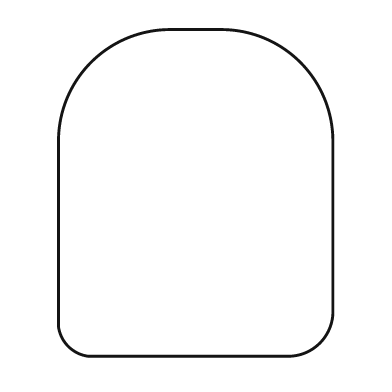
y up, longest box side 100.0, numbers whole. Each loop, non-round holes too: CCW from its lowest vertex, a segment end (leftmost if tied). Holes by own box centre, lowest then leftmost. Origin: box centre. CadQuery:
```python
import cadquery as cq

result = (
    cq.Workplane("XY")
    .moveTo(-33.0, -50.0)
    .lineTo(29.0, -50.0)
    .threePointArc((38.0, -46.0), (42.0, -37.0))
    .lineTo(42.0, 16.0)
    .threePointArc((32.0, 40.0), (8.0, 50.0))
    .lineTo(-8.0, 50.0)
    .threePointArc((-32.0, 40.0), (-42.0, 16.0))
    .lineTo(-42.0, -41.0)
    .threePointArc((-39.0, -47.0), (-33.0, -50.0))
    .close()
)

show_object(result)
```